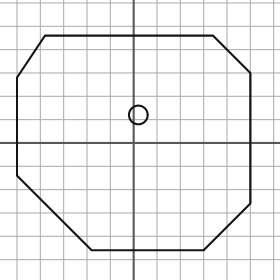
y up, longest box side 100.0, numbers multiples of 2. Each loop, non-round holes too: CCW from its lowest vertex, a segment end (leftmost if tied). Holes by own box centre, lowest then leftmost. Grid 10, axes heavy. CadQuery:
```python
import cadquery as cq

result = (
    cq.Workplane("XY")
    .moveTo(-18.0, -46.0)
    .lineTo(30.0, -46.0)
    .lineTo(50.0, -26.0)
    .lineTo(50.0, 30.0)
    .lineTo(34.0, 46.0)
    .lineTo(-38.0, 46.0)
    .lineTo(-50.0, 28.0)
    .lineTo(-50.0, -14.0)
    .close()
    .moveTo(2.0, 12.0)
    .circle(4.0)
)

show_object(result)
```